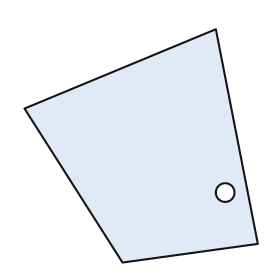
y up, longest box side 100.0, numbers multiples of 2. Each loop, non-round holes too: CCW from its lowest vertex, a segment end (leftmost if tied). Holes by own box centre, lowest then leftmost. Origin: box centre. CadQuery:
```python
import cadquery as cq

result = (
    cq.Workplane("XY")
    .moveTo(-8.0, -50.0)
    .lineTo(50.0, -42.0)
    .lineTo(32.0, 50.0)
    .lineTo(-50.0, 16.0)
    .close()
    .moveTo(36.0, -20.0)
    .circle(4.0)
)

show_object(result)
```